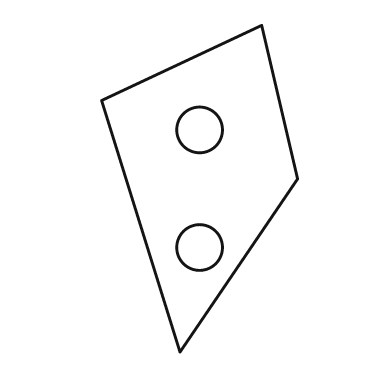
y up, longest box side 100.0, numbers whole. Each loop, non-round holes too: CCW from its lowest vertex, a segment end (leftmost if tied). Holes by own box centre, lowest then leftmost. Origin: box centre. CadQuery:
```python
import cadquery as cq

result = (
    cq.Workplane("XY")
    .moveTo(-6.0, -50.0)
    .lineTo(30.0, 3.0)
    .lineTo(19.0, 50.0)
    .lineTo(-30.0, 27.0)
    .close()
    .moveTo(0.0, -18.0)
    .circle(7.0)
    .moveTo(0.0, 18.0)
    .circle(7.0)
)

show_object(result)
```